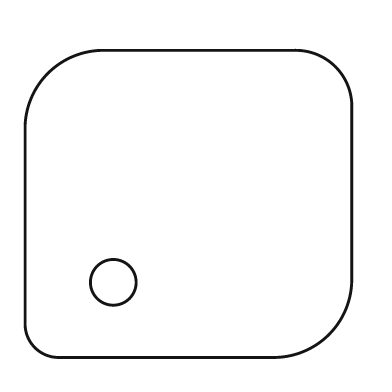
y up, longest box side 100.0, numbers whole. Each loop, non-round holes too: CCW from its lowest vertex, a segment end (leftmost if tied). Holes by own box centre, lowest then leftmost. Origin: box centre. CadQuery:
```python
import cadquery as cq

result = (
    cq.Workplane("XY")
    .moveTo(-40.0, -47.0)
    .lineTo(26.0, -47.0)
    .threePointArc((43.0, -40.0), (50.0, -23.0))
    .lineTo(50.0, 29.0)
    .threePointArc((45.0, 42.0), (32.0, 47.0))
    .lineTo(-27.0, 47.0)
    .threePointArc((-43.0, 40.0), (-50.0, 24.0))
    .lineTo(-50.0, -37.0)
    .threePointArc((-47.0, -44.0), (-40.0, -47.0))
    .close()
    .moveTo(-23.0, -24.0)
    .circle(7.0)
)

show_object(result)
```